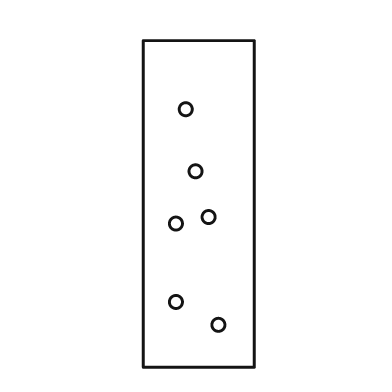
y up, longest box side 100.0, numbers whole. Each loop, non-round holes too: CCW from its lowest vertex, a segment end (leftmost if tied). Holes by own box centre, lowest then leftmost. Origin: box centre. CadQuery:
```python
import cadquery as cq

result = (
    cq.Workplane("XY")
    .moveTo(-17.0, -50.0)
    .lineTo(17.0, -50.0)
    .lineTo(17.0, 50.0)
    .lineTo(-17.0, 50.0)
    .close()
    .moveTo(6.0, -37.0)
    .circle(2.0)
    .moveTo(-7.0, -30.0)
    .circle(2.0)
    .moveTo(-7.0, -6.0)
    .circle(2.0)
    .moveTo(3.0, -4.0)
    .circle(2.0)
    .moveTo(-1.0, 10.0)
    .circle(2.0)
    .moveTo(-4.0, 29.0)
    .circle(2.0)
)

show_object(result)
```